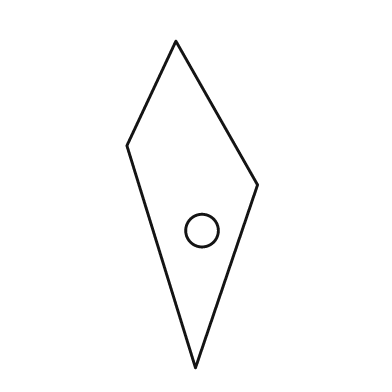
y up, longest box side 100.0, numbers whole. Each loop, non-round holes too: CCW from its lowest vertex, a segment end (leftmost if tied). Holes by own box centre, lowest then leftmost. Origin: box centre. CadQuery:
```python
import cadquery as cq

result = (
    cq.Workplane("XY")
    .moveTo(1.0, -50.0)
    .lineTo(20.0, 6.0)
    .lineTo(-5.0, 50.0)
    .lineTo(-20.0, 18.0)
    .close()
    .moveTo(3.0, -8.0)
    .circle(5.0)
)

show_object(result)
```